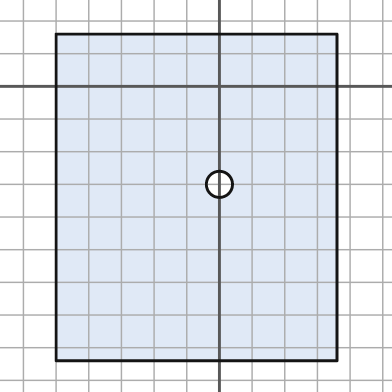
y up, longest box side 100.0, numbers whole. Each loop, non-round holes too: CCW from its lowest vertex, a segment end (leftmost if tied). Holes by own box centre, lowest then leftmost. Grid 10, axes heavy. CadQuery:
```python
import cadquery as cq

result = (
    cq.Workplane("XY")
    .moveTo(-50.0, -84.0)
    .lineTo(36.0, -84.0)
    .lineTo(36.0, 16.0)
    .lineTo(-50.0, 16.0)
    .close()
    .moveTo(0.0, -30.0)
    .circle(4.0)
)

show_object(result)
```